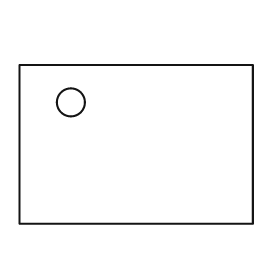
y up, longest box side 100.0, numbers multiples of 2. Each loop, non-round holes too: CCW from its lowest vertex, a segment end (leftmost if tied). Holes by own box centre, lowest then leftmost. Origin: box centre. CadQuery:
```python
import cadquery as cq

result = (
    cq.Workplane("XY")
    .moveTo(-50.0, -34.0)
    .lineTo(50.0, -34.0)
    .lineTo(50.0, 34.0)
    .lineTo(-50.0, 34.0)
    .close()
    .moveTo(-28.0, 18.0)
    .circle(6.0)
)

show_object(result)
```